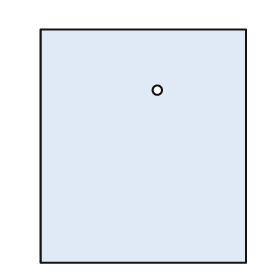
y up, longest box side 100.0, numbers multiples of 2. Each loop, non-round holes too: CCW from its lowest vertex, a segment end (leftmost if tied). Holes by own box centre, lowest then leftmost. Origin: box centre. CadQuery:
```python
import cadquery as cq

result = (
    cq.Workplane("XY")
    .moveTo(-44.0, -50.0)
    .lineTo(44.0, -50.0)
    .lineTo(44.0, 50.0)
    .lineTo(-44.0, 50.0)
    .close()
    .moveTo(6.0, 24.0)
    .circle(2.0)
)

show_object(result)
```